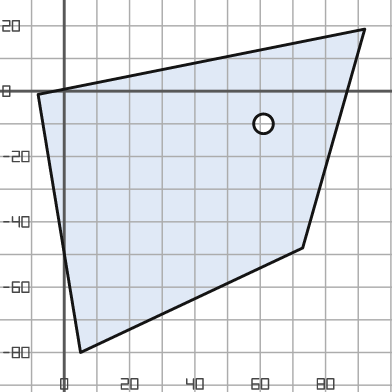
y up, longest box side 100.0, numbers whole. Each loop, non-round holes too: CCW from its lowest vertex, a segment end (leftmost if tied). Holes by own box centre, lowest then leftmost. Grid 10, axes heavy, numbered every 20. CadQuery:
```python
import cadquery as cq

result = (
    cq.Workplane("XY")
    .moveTo(5.0, -80.0)
    .lineTo(73.0, -48.0)
    .lineTo(92.0, 19.0)
    .lineTo(-8.0, -1.0)
    .close()
    .moveTo(61.0, -10.0)
    .circle(3.0)
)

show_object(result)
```